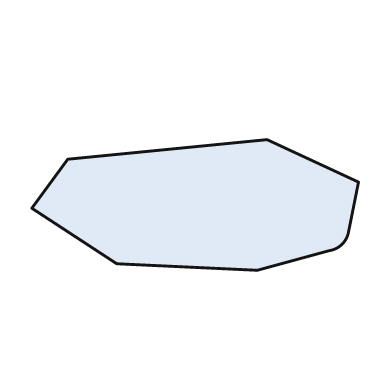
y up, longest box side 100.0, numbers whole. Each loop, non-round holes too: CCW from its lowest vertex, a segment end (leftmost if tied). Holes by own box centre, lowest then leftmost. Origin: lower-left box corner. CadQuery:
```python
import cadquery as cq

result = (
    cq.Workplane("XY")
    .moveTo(69.0, 0.0)
    .lineTo(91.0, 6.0)
    .threePointArc((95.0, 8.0), (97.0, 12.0))
    .lineTo(100.0, 27.0)
    .lineTo(72.0, 40.0)
    .lineTo(11.0, 34.0)
    .lineTo(0.0, 19.0)
    .lineTo(26.0, 2.0)
    .close()
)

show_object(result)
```